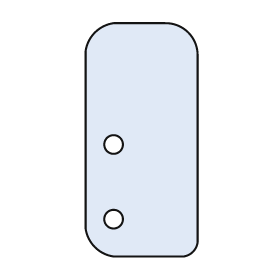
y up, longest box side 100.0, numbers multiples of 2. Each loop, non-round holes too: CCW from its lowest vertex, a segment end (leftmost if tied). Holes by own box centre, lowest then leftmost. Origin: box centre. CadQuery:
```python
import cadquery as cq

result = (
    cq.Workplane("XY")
    .moveTo(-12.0, -50.0)
    .lineTo(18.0, -50.0)
    .threePointArc((22.0, -48.0), (24.0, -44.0))
    .lineTo(24.0, 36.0)
    .threePointArc((20.0, 46.0), (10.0, 50.0))
    .lineTo(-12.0, 50.0)
    .threePointArc((-20.0, 46.0), (-24.0, 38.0))
    .lineTo(-24.0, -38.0)
    .threePointArc((-20.0, -46.0), (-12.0, -50.0))
    .close()
    .moveTo(-12.0, -34.0)
    .circle(4.0)
    .moveTo(-12.0, -2.0)
    .circle(4.0)
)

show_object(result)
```